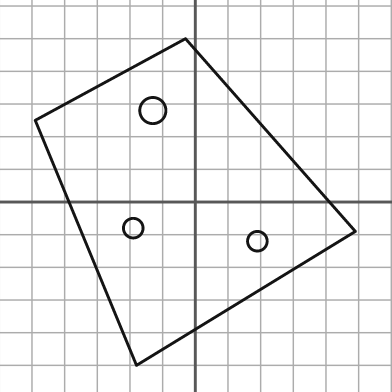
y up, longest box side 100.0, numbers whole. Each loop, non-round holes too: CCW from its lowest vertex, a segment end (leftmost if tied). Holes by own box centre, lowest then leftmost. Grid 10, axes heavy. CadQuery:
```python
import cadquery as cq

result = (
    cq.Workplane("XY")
    .moveTo(-18.0, -50.0)
    .lineTo(49.0, -9.0)
    .lineTo(-3.0, 50.0)
    .lineTo(-49.0, 25.0)
    .close()
    .moveTo(19.0, -12.0)
    .circle(3.0)
    .moveTo(-19.0, -8.0)
    .circle(3.0)
    .moveTo(-13.0, 28.0)
    .circle(4.0)
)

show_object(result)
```